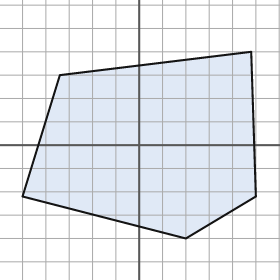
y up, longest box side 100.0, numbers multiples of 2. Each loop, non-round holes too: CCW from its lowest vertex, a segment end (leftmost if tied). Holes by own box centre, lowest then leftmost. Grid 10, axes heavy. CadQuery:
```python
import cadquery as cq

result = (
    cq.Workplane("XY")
    .moveTo(20.0, -40.0)
    .lineTo(50.0, -22.0)
    .lineTo(48.0, 40.0)
    .lineTo(-34.0, 30.0)
    .lineTo(-50.0, -22.0)
    .close()
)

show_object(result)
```